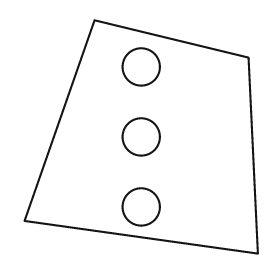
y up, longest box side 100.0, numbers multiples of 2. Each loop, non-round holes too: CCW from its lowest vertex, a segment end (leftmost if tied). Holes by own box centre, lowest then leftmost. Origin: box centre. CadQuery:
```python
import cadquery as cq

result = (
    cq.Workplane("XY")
    .moveTo(50.0, -50.0)
    .lineTo(46.0, 34.0)
    .lineTo(-20.0, 50.0)
    .lineTo(-50.0, -36.0)
    .close()
    .moveTo(0.0, -30.0)
    .circle(8.0)
    .moveTo(0.0, 0.0)
    .circle(8.0)
    .moveTo(0.0, 30.0)
    .circle(8.0)
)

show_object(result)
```